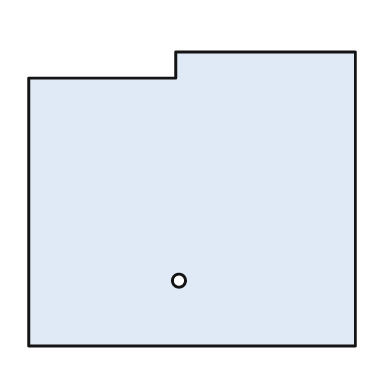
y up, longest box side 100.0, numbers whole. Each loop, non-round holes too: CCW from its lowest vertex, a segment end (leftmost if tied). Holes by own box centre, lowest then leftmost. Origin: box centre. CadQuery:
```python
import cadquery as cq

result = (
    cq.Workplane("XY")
    .moveTo(-50.0, -45.0)
    .lineTo(50.0, -45.0)
    .lineTo(50.0, 45.0)
    .lineTo(-5.0, 45.0)
    .lineTo(-5.0, 37.0)
    .lineTo(-50.0, 37.0)
    .close()
    .moveTo(-4.0, -25.0)
    .circle(2.0)
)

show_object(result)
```